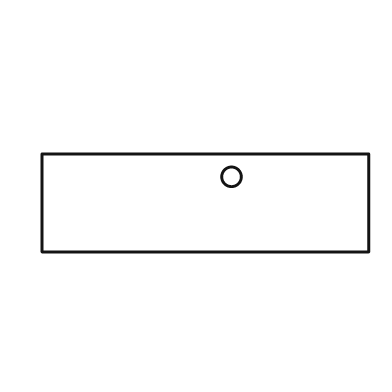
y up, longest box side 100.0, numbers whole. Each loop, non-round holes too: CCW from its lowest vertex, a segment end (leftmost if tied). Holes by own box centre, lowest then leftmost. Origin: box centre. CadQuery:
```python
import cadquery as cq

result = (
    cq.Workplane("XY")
    .moveTo(-50.0, -15.0)
    .lineTo(50.0, -15.0)
    .lineTo(50.0, 15.0)
    .lineTo(-50.0, 15.0)
    .close()
    .moveTo(8.0, 8.0)
    .circle(3.0)
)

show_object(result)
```